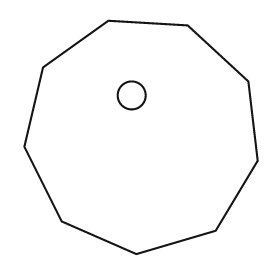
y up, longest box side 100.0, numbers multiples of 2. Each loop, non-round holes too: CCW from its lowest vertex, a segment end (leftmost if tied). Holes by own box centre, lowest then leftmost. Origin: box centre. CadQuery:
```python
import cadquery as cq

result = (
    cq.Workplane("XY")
    .moveTo(-2.0, -50.0)
    .lineTo(32.0, -40.0)
    .lineTo(50.0, -10.0)
    .lineTo(46.0, 24.0)
    .lineTo(20.0, 48.0)
    .lineTo(-14.0, 50.0)
    .lineTo(-42.0, 30.0)
    .lineTo(-50.0, -4.0)
    .lineTo(-34.0, -36.0)
    .close()
    .moveTo(-4.0, 18.0)
    .circle(6.0)
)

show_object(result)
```